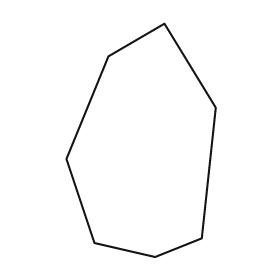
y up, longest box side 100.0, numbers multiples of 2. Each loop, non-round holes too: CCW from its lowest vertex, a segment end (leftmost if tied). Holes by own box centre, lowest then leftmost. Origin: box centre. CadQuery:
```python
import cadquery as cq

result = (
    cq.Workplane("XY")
    .moveTo(6.0, -50.0)
    .lineTo(26.0, -42.0)
    .lineTo(32.0, 14.0)
    .lineTo(10.0, 50.0)
    .lineTo(-14.0, 36.0)
    .lineTo(-32.0, -8.0)
    .lineTo(-20.0, -44.0)
    .close()
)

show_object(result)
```